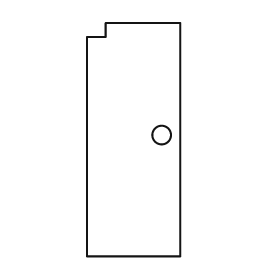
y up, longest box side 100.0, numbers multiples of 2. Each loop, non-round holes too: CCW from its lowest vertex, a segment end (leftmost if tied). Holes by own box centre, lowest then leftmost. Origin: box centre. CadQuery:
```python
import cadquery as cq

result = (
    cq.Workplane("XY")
    .moveTo(-20.0, -50.0)
    .lineTo(20.0, -50.0)
    .lineTo(20.0, 50.0)
    .lineTo(-12.0, 50.0)
    .lineTo(-12.0, 44.0)
    .lineTo(-20.0, 44.0)
    .close()
    .moveTo(12.0, 2.0)
    .circle(4.0)
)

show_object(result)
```